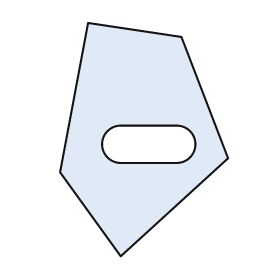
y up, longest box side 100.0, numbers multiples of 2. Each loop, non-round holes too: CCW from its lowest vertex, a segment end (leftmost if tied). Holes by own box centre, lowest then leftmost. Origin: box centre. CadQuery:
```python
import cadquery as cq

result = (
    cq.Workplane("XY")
    .moveTo(-10.0, -50.0)
    .lineTo(36.0, -8.0)
    .lineTo(16.0, 44.0)
    .lineTo(-24.0, 50.0)
    .lineTo(-36.0, -14.0)
    .close()
    .moveTo(-10.0, -10.0)
    .lineTo(14.0, -10.0)
    .threePointArc((22.0, -2.0), (14.0, 6.0))
    .lineTo(-10.0, 6.0)
    .threePointArc((-18.0, -2.0), (-10.0, -10.0))
    .close()
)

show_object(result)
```